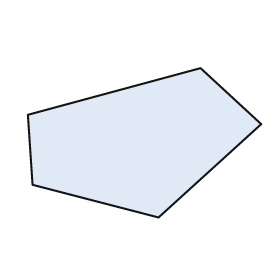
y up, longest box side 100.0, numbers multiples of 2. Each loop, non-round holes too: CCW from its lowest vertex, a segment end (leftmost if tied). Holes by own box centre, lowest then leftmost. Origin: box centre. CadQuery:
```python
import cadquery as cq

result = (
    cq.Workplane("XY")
    .moveTo(6.0, -32.0)
    .lineTo(50.0, 8.0)
    .lineTo(24.0, 32.0)
    .lineTo(-50.0, 12.0)
    .lineTo(-48.0, -18.0)
    .close()
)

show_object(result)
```